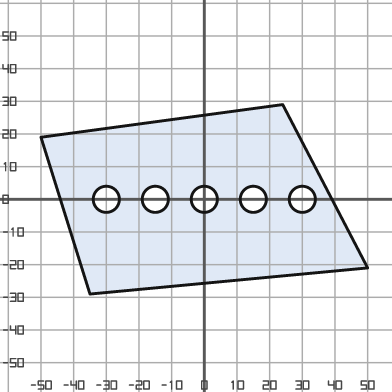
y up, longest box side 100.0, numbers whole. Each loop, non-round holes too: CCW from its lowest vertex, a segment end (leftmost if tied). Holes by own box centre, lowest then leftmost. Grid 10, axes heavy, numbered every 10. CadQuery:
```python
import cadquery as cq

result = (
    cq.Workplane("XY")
    .moveTo(-35.0, -29.0)
    .lineTo(50.0, -21.0)
    .lineTo(24.0, 29.0)
    .lineTo(-50.0, 19.0)
    .close()
    .moveTo(-30.0, 0.0)
    .circle(4.0)
    .moveTo(-15.0, 0.0)
    .circle(4.0)
    .moveTo(0.0, 0.0)
    .circle(4.0)
    .moveTo(15.0, 0.0)
    .circle(4.0)
    .moveTo(30.0, 0.0)
    .circle(4.0)
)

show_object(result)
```